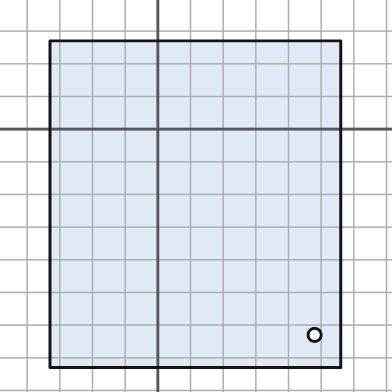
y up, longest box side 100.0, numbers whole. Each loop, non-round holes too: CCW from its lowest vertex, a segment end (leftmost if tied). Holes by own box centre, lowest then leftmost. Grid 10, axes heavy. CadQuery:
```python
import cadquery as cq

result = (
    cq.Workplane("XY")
    .moveTo(-33.0, -73.0)
    .lineTo(56.0, -73.0)
    .lineTo(56.0, 27.0)
    .lineTo(-33.0, 27.0)
    .close()
    .moveTo(48.0, -63.0)
    .circle(2.0)
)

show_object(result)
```